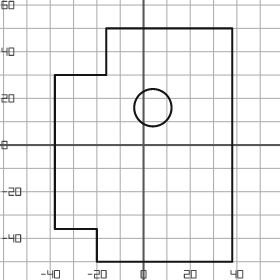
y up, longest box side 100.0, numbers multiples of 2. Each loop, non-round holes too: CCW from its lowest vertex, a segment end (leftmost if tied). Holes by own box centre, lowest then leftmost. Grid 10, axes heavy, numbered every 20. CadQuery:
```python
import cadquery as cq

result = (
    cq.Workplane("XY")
    .moveTo(-20.0, -50.0)
    .lineTo(38.0, -50.0)
    .lineTo(38.0, 50.0)
    .lineTo(-16.0, 50.0)
    .lineTo(-16.0, 30.0)
    .lineTo(-38.0, 30.0)
    .lineTo(-38.0, -36.0)
    .lineTo(-20.0, -36.0)
    .close()
    .moveTo(4.0, 16.0)
    .circle(8.0)
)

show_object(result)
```